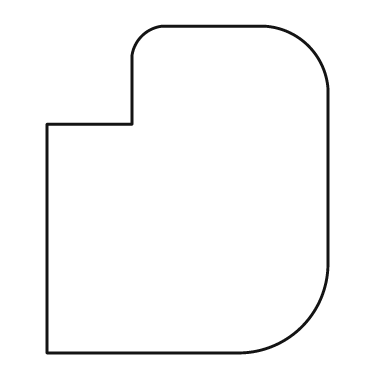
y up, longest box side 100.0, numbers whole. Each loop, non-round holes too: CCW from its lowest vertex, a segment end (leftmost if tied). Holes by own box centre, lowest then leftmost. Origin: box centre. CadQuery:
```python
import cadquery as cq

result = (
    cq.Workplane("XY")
    .moveTo(-43.0, -50.0)
    .lineTo(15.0, -50.0)
    .threePointArc((35.0, -42.0), (43.0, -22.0))
    .lineTo(43.0, 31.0)
    .threePointArc((37.0, 44.0), (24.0, 50.0))
    .lineTo(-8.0, 50.0)
    .threePointArc((-14.0, 47.0), (-17.0, 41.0))
    .lineTo(-17.0, 20.0)
    .lineTo(-43.0, 20.0)
    .close()
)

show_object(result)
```